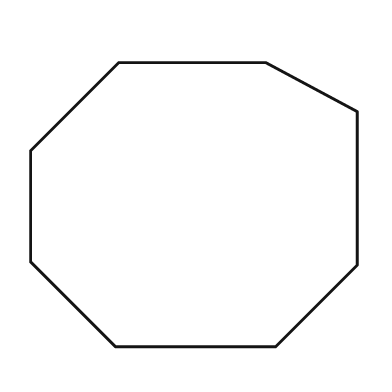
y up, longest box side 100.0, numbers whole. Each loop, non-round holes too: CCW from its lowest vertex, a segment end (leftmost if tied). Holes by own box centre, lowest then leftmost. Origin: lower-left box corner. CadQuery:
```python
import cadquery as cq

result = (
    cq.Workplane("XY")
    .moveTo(26.0, 0.0)
    .lineTo(75.0, 0.0)
    .lineTo(100.0, 25.0)
    .lineTo(100.0, 72.0)
    .lineTo(72.0, 87.0)
    .lineTo(27.0, 87.0)
    .lineTo(0.0, 60.0)
    .lineTo(0.0, 26.0)
    .close()
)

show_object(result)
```